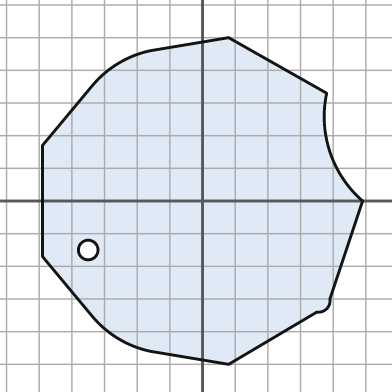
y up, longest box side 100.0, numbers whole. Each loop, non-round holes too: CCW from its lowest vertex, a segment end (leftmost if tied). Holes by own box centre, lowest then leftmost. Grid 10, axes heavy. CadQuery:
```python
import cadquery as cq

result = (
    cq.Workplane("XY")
    .moveTo(8.0, -50.0)
    .lineTo(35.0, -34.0)
    .threePointArc((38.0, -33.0), (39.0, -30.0))
    .lineTo(49.0, 0.0)
    .threePointArc((39.0, 15.0), (38.0, 33.0))
    .lineTo(8.0, 50.0)
    .lineTo(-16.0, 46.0)
    .threePointArc((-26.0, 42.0), (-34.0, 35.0))
    .lineTo(-49.0, 17.0)
    .lineTo(-49.0, -17.0)
    .lineTo(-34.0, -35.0)
    .threePointArc((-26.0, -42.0), (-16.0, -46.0))
    .close()
    .moveTo(-35.0, -15.0)
    .circle(3.0)
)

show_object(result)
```